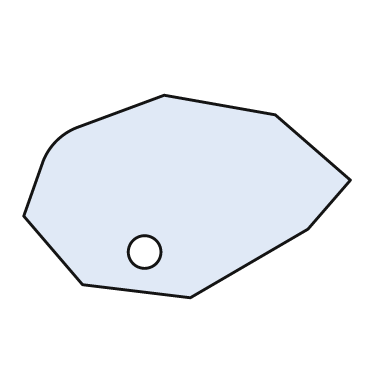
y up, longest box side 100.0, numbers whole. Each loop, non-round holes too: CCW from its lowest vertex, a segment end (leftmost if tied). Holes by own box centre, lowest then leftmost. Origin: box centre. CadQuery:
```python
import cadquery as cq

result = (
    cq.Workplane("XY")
    .moveTo(1.0, -31.0)
    .lineTo(37.0, -10.0)
    .lineTo(50.0, 5.0)
    .lineTo(27.0, 25.0)
    .lineTo(-7.0, 31.0)
    .lineTo(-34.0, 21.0)
    .threePointArc((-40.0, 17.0), (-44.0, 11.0))
    .lineTo(-50.0, -6.0)
    .lineTo(-32.0, -27.0)
    .close()
    .moveTo(-13.0, -17.0)
    .circle(5.0)
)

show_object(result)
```